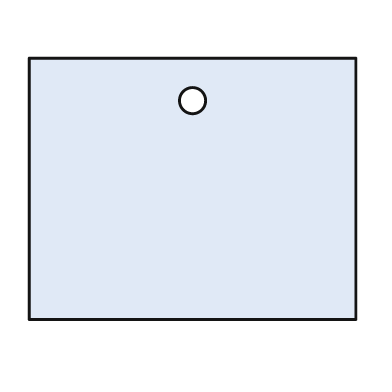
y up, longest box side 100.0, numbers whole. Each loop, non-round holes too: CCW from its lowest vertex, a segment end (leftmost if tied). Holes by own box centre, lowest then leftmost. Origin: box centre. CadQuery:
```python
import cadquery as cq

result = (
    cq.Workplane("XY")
    .moveTo(-50.0, -40.0)
    .lineTo(50.0, -40.0)
    .lineTo(50.0, 40.0)
    .lineTo(-50.0, 40.0)
    .close()
    .moveTo(0.0, 27.0)
    .circle(4.0)
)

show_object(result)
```